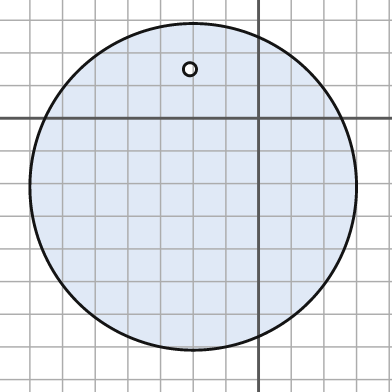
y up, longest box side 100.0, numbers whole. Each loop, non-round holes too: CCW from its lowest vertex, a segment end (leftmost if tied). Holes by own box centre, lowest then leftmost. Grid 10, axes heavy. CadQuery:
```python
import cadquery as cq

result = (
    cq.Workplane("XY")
    .moveTo(-20.0, -21.0)
    .circle(50.0)
    .moveTo(-21.0, 15.0)
    .circle(2.0)
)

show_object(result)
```